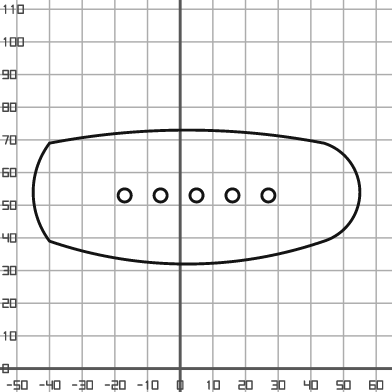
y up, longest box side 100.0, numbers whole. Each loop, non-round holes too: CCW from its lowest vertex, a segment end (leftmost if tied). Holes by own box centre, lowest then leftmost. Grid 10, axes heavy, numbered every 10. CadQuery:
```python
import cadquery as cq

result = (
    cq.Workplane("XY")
    .moveTo(-40.0, 39.0)
    .threePointArc((2.0, 32.0), (44.0, 39.0))
    .threePointArc((55.0, 54.0), (44.0, 69.0))
    .threePointArc((2.0, 73.0), (-40.0, 69.0))
    .threePointArc((-45.0, 54.0), (-40.0, 39.0))
    .close()
    .moveTo(-17.0, 53.0)
    .circle(2.0)
    .moveTo(-6.0, 53.0)
    .circle(2.0)
    .moveTo(5.0, 53.0)
    .circle(2.0)
    .moveTo(16.0, 53.0)
    .circle(2.0)
    .moveTo(27.0, 53.0)
    .circle(2.0)
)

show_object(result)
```